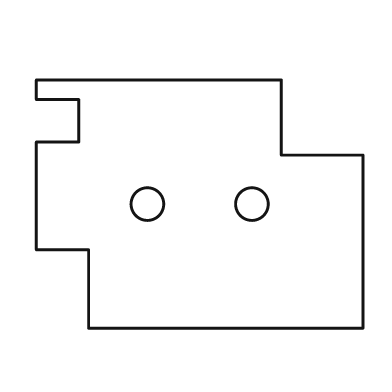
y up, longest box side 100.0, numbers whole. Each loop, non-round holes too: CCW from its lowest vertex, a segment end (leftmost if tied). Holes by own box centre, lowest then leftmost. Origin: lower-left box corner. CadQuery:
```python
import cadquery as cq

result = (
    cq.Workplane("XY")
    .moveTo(16.0, 0.0)
    .lineTo(100.0, 0.0)
    .lineTo(100.0, 53.0)
    .lineTo(75.0, 53.0)
    .lineTo(75.0, 76.0)
    .lineTo(0.0, 76.0)
    .lineTo(0.0, 70.0)
    .lineTo(13.0, 70.0)
    .lineTo(13.0, 57.0)
    .lineTo(0.0, 57.0)
    .lineTo(0.0, 24.0)
    .lineTo(16.0, 24.0)
    .close()
    .moveTo(34.0, 38.0)
    .circle(5.0)
    .moveTo(66.0, 38.0)
    .circle(5.0)
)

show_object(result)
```